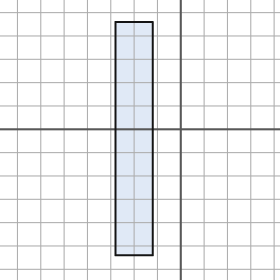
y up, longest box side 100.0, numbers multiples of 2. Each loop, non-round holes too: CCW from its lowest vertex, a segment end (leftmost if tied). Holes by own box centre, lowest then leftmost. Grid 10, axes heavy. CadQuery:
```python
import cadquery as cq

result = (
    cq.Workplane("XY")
    .moveTo(-28.0, -54.0)
    .lineTo(-12.0, -54.0)
    .lineTo(-12.0, 46.0)
    .lineTo(-28.0, 46.0)
    .close()
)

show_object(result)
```